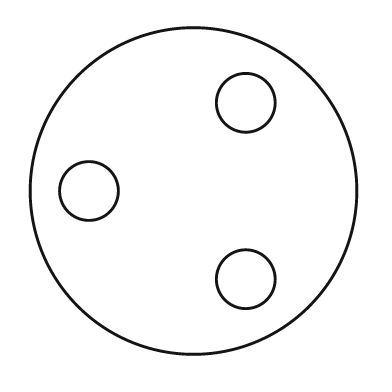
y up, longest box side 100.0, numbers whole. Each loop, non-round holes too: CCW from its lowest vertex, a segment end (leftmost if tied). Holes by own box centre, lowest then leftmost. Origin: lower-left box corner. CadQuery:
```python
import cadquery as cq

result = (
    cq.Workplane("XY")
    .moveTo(50.0, 50.0)
    .circle(50.0)
    .moveTo(66.0, 23.0)
    .circle(9.0)
    .moveTo(18.0, 50.0)
    .circle(9.0)
    .moveTo(66.0, 77.0)
    .circle(9.0)
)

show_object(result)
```